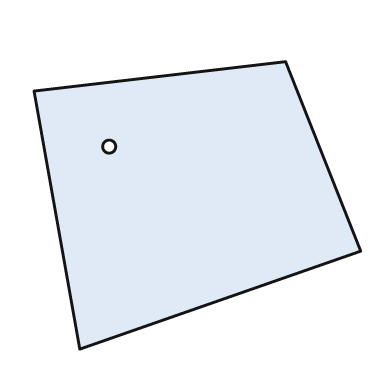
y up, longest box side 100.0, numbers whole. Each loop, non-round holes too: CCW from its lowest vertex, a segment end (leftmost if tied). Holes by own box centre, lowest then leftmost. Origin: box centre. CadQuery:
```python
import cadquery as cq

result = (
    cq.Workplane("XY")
    .moveTo(-36.0, -44.0)
    .lineTo(50.0, -14.0)
    .lineTo(27.0, 44.0)
    .lineTo(-50.0, 35.0)
    .close()
    .moveTo(-27.0, 18.0)
    .circle(2.0)
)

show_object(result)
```